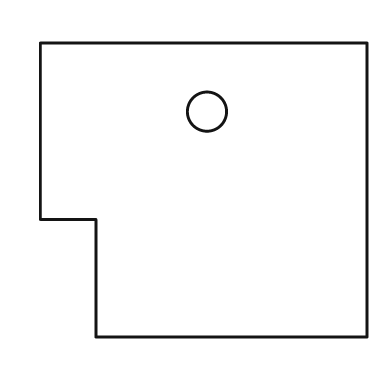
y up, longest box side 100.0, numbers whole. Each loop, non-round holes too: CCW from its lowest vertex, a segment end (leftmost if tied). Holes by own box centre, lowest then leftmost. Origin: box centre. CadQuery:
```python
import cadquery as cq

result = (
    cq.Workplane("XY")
    .moveTo(-33.0, -45.0)
    .lineTo(50.0, -45.0)
    .lineTo(50.0, 45.0)
    .lineTo(-50.0, 45.0)
    .lineTo(-50.0, -9.0)
    .lineTo(-33.0, -9.0)
    .close()
    .moveTo(1.0, 24.0)
    .circle(6.0)
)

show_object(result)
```